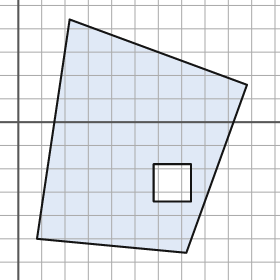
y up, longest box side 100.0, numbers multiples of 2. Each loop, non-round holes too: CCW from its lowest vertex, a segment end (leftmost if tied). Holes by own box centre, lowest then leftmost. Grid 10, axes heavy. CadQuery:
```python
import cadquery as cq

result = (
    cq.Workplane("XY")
    .moveTo(72.0, -56.0)
    .lineTo(98.0, 16.0)
    .lineTo(22.0, 44.0)
    .lineTo(8.0, -50.0)
    .close()
    .moveTo(58.0, -34.0)
    .lineTo(74.0, -34.0)
    .lineTo(74.0, -18.0)
    .lineTo(58.0, -18.0)
    .close()
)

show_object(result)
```